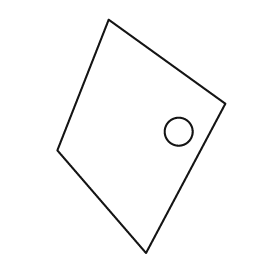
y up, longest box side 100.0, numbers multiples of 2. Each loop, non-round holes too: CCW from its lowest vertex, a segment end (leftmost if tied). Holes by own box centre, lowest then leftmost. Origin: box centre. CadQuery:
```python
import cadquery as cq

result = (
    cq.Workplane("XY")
    .moveTo(2.0, -50.0)
    .lineTo(36.0, 14.0)
    .lineTo(-14.0, 50.0)
    .lineTo(-36.0, -6.0)
    .close()
    .moveTo(16.0, 2.0)
    .circle(6.0)
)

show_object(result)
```